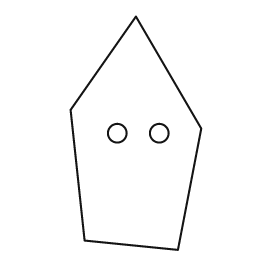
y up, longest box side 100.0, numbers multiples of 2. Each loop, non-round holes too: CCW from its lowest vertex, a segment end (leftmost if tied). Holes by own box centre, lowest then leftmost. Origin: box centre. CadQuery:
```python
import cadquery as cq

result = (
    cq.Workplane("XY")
    .moveTo(18.0, -50.0)
    .lineTo(28.0, 2.0)
    .lineTo(0.0, 50.0)
    .lineTo(-28.0, 10.0)
    .lineTo(-22.0, -46.0)
    .close()
    .moveTo(-8.0, 0.0)
    .circle(4.0)
    .moveTo(10.0, 0.0)
    .circle(4.0)
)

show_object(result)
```